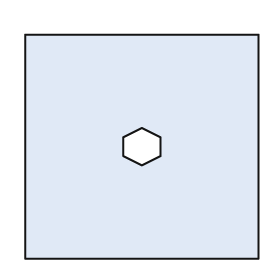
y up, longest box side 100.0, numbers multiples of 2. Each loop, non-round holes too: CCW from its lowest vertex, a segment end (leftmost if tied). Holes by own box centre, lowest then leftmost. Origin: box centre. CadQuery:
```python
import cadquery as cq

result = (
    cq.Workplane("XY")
    .moveTo(-50.0, -48.0)
    .lineTo(50.0, -48.0)
    .lineTo(50.0, 48.0)
    .lineTo(-50.0, 48.0)
    .close()
    .moveTo(0.0, -8.0)
    .lineTo(8.0, -4.0)
    .lineTo(8.0, 4.0)
    .lineTo(0.0, 8.0)
    .lineTo(-8.0, 4.0)
    .lineTo(-8.0, -4.0)
    .close()
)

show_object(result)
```